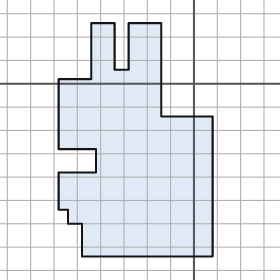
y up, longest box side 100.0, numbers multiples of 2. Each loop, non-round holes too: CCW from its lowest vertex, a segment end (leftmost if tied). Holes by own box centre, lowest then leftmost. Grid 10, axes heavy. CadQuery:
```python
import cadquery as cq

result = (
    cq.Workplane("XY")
    .moveTo(-48.0, -74.0)
    .lineTo(8.0, -74.0)
    .lineTo(8.0, -14.0)
    .lineTo(-14.0, -14.0)
    .lineTo(-14.0, 26.0)
    .lineTo(-28.0, 26.0)
    .lineTo(-28.0, 6.0)
    .lineTo(-34.0, 6.0)
    .lineTo(-34.0, 26.0)
    .lineTo(-44.0, 26.0)
    .lineTo(-44.0, 2.0)
    .lineTo(-58.0, 2.0)
    .lineTo(-58.0, -28.0)
    .lineTo(-42.0, -28.0)
    .lineTo(-42.0, -38.0)
    .lineTo(-58.0, -38.0)
    .lineTo(-58.0, -54.0)
    .lineTo(-54.0, -54.0)
    .lineTo(-54.0, -60.0)
    .lineTo(-48.0, -60.0)
    .close()
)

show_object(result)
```